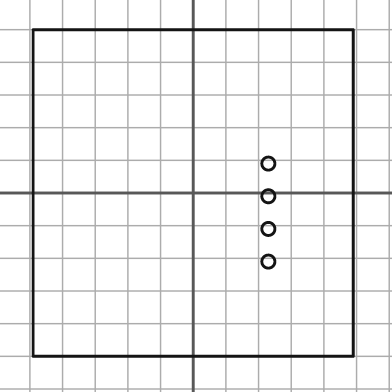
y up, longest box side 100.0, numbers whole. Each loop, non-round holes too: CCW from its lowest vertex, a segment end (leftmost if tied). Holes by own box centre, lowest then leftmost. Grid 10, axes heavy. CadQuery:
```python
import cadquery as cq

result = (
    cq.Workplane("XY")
    .moveTo(-49.0, -50.0)
    .lineTo(49.0, -50.0)
    .lineTo(49.0, 50.0)
    .lineTo(-49.0, 50.0)
    .close()
    .moveTo(23.0, -21.0)
    .circle(2.0)
    .moveTo(23.0, -11.0)
    .circle(2.0)
    .moveTo(23.0, -1.0)
    .circle(2.0)
    .moveTo(23.0, 9.0)
    .circle(2.0)
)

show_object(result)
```